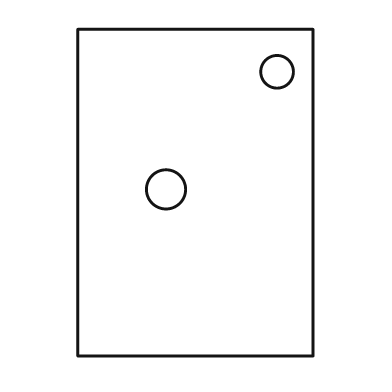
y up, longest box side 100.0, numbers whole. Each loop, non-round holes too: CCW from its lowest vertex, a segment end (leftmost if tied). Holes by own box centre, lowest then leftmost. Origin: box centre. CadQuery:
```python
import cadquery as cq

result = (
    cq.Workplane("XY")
    .moveTo(-36.0, -50.0)
    .lineTo(36.0, -50.0)
    .lineTo(36.0, 50.0)
    .lineTo(-36.0, 50.0)
    .close()
    .moveTo(-9.0, 1.0)
    .circle(6.0)
    .moveTo(25.0, 37.0)
    .circle(5.0)
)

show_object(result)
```